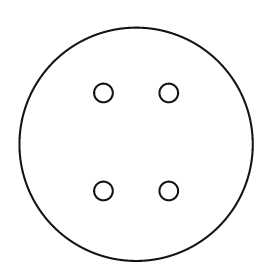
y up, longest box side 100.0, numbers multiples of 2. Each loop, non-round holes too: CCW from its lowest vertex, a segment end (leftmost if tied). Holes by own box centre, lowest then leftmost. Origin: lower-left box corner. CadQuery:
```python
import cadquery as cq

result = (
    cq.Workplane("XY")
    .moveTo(50.0, 50.0)
    .circle(50.0)
    .moveTo(36.0, 30.0)
    .circle(4.0)
    .moveTo(64.0, 30.0)
    .circle(4.0)
    .moveTo(36.0, 72.0)
    .circle(4.0)
    .moveTo(64.0, 72.0)
    .circle(4.0)
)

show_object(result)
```